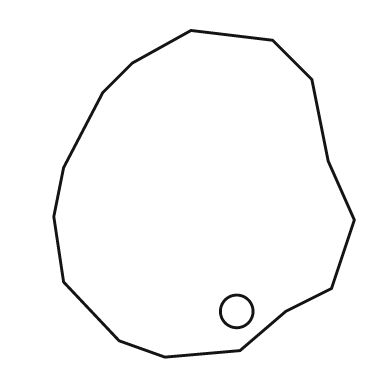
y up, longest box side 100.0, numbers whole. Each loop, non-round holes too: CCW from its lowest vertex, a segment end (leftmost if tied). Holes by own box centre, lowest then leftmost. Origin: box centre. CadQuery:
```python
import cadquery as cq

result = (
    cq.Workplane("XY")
    .moveTo(-12.0, -50.0)
    .lineTo(11.0, -48.0)
    .lineTo(25.0, -36.0)
    .lineTo(39.0, -29.0)
    .lineTo(46.0, -8.0)
    .lineTo(38.0, 10.0)
    .lineTo(33.0, 35.0)
    .lineTo(21.0, 47.0)
    .lineTo(-4.0, 50.0)
    .lineTo(-22.0, 40.0)
    .lineTo(-31.0, 31.0)
    .lineTo(-43.0, 8.0)
    .lineTo(-46.0, -7.0)
    .lineTo(-43.0, -27.0)
    .lineTo(-26.0, -45.0)
    .close()
    .moveTo(10.0, -36.0)
    .circle(5.0)
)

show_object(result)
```